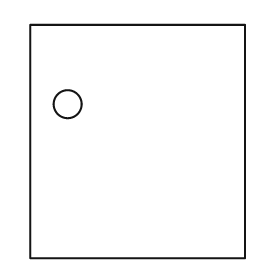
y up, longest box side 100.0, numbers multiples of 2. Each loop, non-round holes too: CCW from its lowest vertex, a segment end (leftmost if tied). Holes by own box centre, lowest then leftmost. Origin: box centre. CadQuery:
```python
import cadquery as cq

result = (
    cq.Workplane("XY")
    .moveTo(-46.0, -50.0)
    .lineTo(46.0, -50.0)
    .lineTo(46.0, 50.0)
    .lineTo(-46.0, 50.0)
    .close()
    .moveTo(-30.0, 16.0)
    .circle(6.0)
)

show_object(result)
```